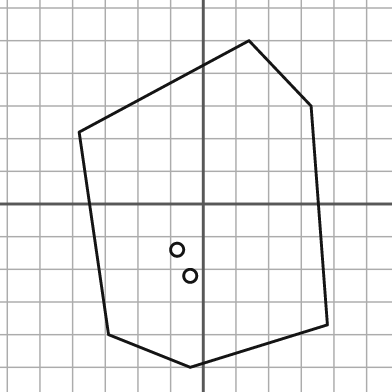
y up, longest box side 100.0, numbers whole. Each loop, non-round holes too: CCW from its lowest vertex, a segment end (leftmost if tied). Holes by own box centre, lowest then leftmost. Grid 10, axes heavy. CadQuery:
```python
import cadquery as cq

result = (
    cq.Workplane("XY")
    .moveTo(-4.0, -50.0)
    .lineTo(38.0, -37.0)
    .lineTo(33.0, 30.0)
    .lineTo(14.0, 50.0)
    .lineTo(-38.0, 22.0)
    .lineTo(-29.0, -40.0)
    .close()
    .moveTo(-4.0, -22.0)
    .circle(2.0)
    .moveTo(-8.0, -14.0)
    .circle(2.0)
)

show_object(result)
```